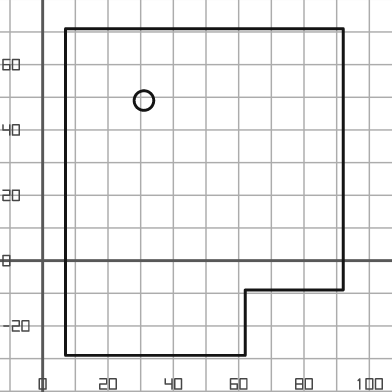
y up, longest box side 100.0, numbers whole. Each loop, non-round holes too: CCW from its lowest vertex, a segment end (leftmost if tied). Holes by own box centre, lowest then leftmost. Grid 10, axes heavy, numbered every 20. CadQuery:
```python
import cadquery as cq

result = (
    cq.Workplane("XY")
    .moveTo(7.0, -29.0)
    .lineTo(62.0, -29.0)
    .lineTo(62.0, -9.0)
    .lineTo(92.0, -9.0)
    .lineTo(92.0, 71.0)
    .lineTo(7.0, 71.0)
    .close()
    .moveTo(31.0, 49.0)
    .circle(3.0)
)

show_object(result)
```